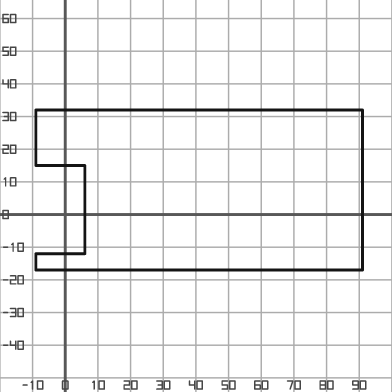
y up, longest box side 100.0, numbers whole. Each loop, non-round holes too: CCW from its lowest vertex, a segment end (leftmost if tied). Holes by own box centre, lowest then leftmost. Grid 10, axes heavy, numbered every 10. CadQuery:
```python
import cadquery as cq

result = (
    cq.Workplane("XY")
    .moveTo(-9.0, -17.0)
    .lineTo(91.0, -17.0)
    .lineTo(91.0, 32.0)
    .lineTo(-9.0, 32.0)
    .lineTo(-9.0, 15.0)
    .lineTo(6.0, 15.0)
    .lineTo(6.0, -12.0)
    .lineTo(-9.0, -12.0)
    .close()
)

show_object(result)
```